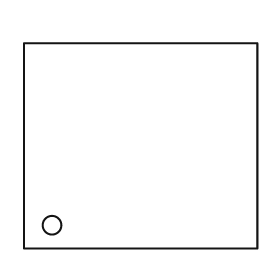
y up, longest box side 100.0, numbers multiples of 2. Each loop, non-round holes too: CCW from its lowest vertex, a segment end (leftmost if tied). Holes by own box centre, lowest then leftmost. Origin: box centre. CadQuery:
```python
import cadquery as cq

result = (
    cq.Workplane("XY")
    .moveTo(-50.0, -44.0)
    .lineTo(50.0, -44.0)
    .lineTo(50.0, 44.0)
    .lineTo(-50.0, 44.0)
    .close()
    .moveTo(-38.0, -34.0)
    .circle(4.0)
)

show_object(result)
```